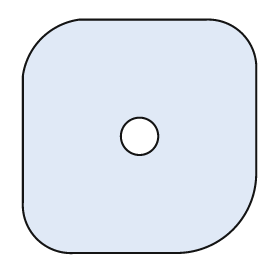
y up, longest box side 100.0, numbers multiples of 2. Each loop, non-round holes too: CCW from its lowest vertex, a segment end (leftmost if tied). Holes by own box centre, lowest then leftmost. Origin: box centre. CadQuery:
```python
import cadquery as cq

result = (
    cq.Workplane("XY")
    .moveTo(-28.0, -50.0)
    .lineTo(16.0, -50.0)
    .threePointArc((40.0, -40.0), (50.0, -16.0))
    .lineTo(50.0, 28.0)
    .threePointArc((44.0, 44.0), (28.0, 50.0))
    .lineTo(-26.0, 50.0)
    .threePointArc((-42.0, 42.0), (-50.0, 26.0))
    .lineTo(-50.0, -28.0)
    .threePointArc((-44.0, -44.0), (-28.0, -50.0))
    .close()
    .moveTo(0.0, 0.0)
    .circle(8.0)
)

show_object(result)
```